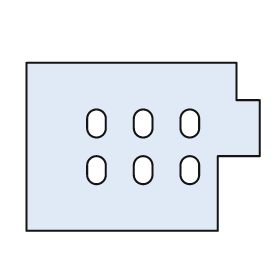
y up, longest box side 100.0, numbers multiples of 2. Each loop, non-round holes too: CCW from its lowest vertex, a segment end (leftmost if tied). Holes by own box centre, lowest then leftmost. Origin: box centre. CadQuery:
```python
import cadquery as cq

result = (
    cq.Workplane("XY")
    .moveTo(-50.0, -36.0)
    .lineTo(32.0, -36.0)
    .lineTo(32.0, -4.0)
    .lineTo(50.0, -4.0)
    .lineTo(50.0, 20.0)
    .lineTo(40.0, 20.0)
    .lineTo(40.0, 36.0)
    .lineTo(-50.0, 36.0)
    .close()
    .moveTo(-24.0, -12.0)
    .threePointArc((-20.0, -16.0), (-16.0, -12.0))
    .lineTo(-16.0, -8.0)
    .threePointArc((-20.0, -4.0), (-24.0, -8.0))
    .close()
    .moveTo(-4.0, -12.0)
    .threePointArc((0.0, -16.0), (4.0, -12.0))
    .lineTo(4.0, -8.0)
    .threePointArc((0.0, -4.0), (-4.0, -8.0))
    .close()
    .moveTo(16.0, -12.0)
    .threePointArc((20.0, -16.0), (24.0, -12.0))
    .lineTo(24.0, -8.0)
    .threePointArc((20.0, -4.0), (16.0, -8.0))
    .close()
    .moveTo(-24.0, 8.0)
    .threePointArc((-20.0, 4.0), (-16.0, 8.0))
    .lineTo(-16.0, 12.0)
    .threePointArc((-20.0, 16.0), (-24.0, 12.0))
    .close()
    .moveTo(-4.0, 8.0)
    .threePointArc((0.0, 4.0), (4.0, 8.0))
    .lineTo(4.0, 12.0)
    .threePointArc((0.0, 16.0), (-4.0, 12.0))
    .close()
    .moveTo(16.0, 8.0)
    .threePointArc((20.0, 4.0), (24.0, 8.0))
    .lineTo(24.0, 12.0)
    .threePointArc((20.0, 16.0), (16.0, 12.0))
    .close()
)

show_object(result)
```